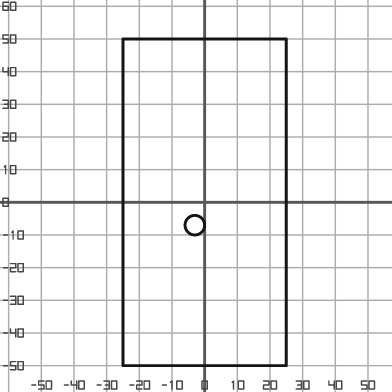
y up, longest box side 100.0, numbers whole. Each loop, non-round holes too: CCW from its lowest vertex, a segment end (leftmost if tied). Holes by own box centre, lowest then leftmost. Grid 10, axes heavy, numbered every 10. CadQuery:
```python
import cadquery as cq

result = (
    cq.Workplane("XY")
    .moveTo(-25.0, -50.0)
    .lineTo(25.0, -50.0)
    .lineTo(25.0, 50.0)
    .lineTo(-25.0, 50.0)
    .close()
    .moveTo(-3.0, -7.0)
    .circle(3.0)
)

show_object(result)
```